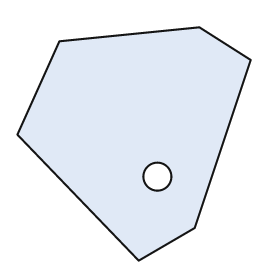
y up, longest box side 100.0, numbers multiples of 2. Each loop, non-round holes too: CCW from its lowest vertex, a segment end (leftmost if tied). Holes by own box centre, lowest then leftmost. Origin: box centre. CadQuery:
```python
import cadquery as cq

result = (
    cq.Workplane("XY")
    .moveTo(2.0, -50.0)
    .lineTo(26.0, -36.0)
    .lineTo(50.0, 36.0)
    .lineTo(28.0, 50.0)
    .lineTo(-32.0, 44.0)
    .lineTo(-50.0, 4.0)
    .close()
    .moveTo(10.0, -14.0)
    .circle(6.0)
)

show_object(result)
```